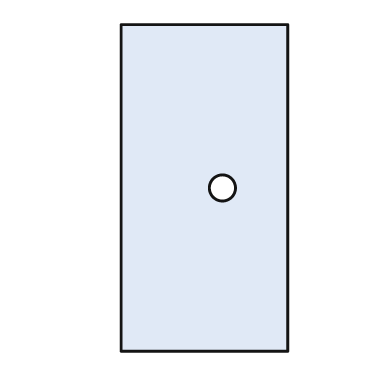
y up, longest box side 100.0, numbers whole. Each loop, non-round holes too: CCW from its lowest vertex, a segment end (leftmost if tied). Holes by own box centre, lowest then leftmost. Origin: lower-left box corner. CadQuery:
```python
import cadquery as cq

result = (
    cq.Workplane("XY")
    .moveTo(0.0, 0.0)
    .lineTo(51.0, 0.0)
    .lineTo(51.0, 100.0)
    .lineTo(0.0, 100.0)
    .close()
    .moveTo(31.0, 50.0)
    .circle(4.0)
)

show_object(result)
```